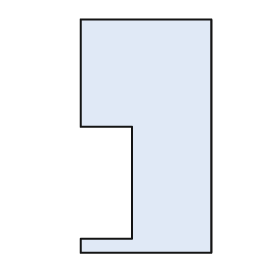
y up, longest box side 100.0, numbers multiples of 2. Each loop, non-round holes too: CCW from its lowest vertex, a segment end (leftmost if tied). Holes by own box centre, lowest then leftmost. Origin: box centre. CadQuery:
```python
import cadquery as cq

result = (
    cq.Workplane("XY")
    .moveTo(-28.0, -50.0)
    .lineTo(28.0, -50.0)
    .lineTo(28.0, 50.0)
    .lineTo(-28.0, 50.0)
    .lineTo(-28.0, 4.0)
    .lineTo(-6.0, 4.0)
    .lineTo(-6.0, -44.0)
    .lineTo(-28.0, -44.0)
    .close()
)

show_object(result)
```